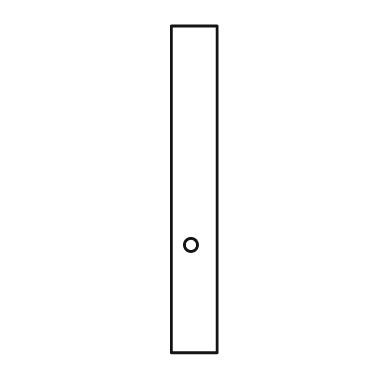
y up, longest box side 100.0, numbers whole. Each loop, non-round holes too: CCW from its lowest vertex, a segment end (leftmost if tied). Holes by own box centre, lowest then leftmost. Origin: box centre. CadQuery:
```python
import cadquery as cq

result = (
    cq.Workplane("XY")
    .moveTo(-7.0, -50.0)
    .lineTo(7.0, -50.0)
    .lineTo(7.0, 50.0)
    .lineTo(-7.0, 50.0)
    .close()
    .moveTo(-1.0, -17.0)
    .circle(2.0)
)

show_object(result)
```